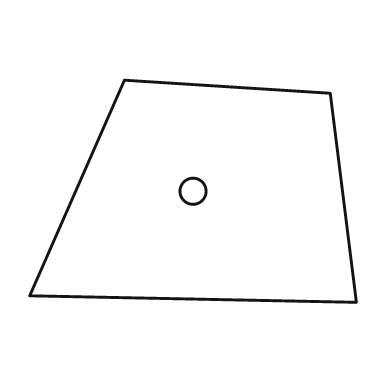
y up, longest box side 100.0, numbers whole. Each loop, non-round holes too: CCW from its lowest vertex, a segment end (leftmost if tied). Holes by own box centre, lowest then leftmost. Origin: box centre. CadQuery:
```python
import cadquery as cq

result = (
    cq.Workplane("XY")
    .moveTo(50.0, -34.0)
    .lineTo(42.0, 30.0)
    .lineTo(-21.0, 34.0)
    .lineTo(-50.0, -32.0)
    .close()
    .moveTo(0.0, 0.0)
    .circle(4.0)
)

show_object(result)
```